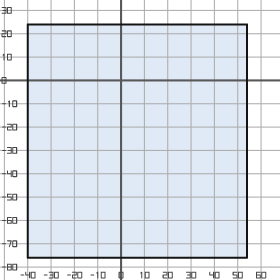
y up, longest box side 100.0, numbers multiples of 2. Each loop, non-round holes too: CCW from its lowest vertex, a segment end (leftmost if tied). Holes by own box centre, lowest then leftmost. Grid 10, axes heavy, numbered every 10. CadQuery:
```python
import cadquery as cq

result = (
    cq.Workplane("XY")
    .moveTo(-40.0, -76.0)
    .lineTo(54.0, -76.0)
    .lineTo(54.0, 24.0)
    .lineTo(-40.0, 24.0)
    .close()
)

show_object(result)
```